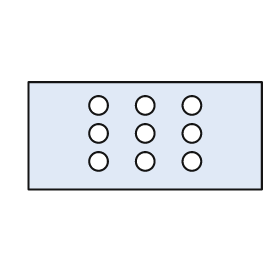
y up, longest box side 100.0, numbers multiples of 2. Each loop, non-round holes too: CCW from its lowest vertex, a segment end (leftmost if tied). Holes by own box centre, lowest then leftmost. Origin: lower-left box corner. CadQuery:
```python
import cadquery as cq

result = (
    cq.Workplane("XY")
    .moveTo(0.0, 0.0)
    .lineTo(100.0, 0.0)
    .lineTo(100.0, 46.0)
    .lineTo(0.0, 46.0)
    .close()
    .moveTo(30.0, 12.0)
    .circle(4.0)
    .moveTo(50.0, 12.0)
    .circle(4.0)
    .moveTo(70.0, 12.0)
    .circle(4.0)
    .moveTo(30.0, 24.0)
    .circle(4.0)
    .moveTo(50.0, 24.0)
    .circle(4.0)
    .moveTo(70.0, 24.0)
    .circle(4.0)
    .moveTo(30.0, 36.0)
    .circle(4.0)
    .moveTo(50.0, 36.0)
    .circle(4.0)
    .moveTo(70.0, 36.0)
    .circle(4.0)
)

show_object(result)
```